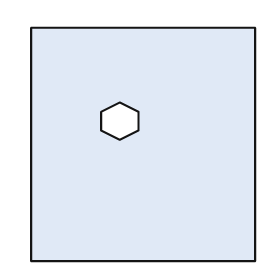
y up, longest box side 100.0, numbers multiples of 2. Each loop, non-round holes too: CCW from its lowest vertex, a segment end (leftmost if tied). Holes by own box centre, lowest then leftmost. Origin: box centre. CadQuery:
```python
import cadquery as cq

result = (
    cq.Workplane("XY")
    .moveTo(-48.0, -50.0)
    .lineTo(48.0, -50.0)
    .lineTo(48.0, 50.0)
    .lineTo(-48.0, 50.0)
    .close()
    .moveTo(-10.0, 2.0)
    .lineTo(-2.0, 6.0)
    .lineTo(-2.0, 14.0)
    .lineTo(-10.0, 18.0)
    .lineTo(-18.0, 14.0)
    .lineTo(-18.0, 6.0)
    .close()
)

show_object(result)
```